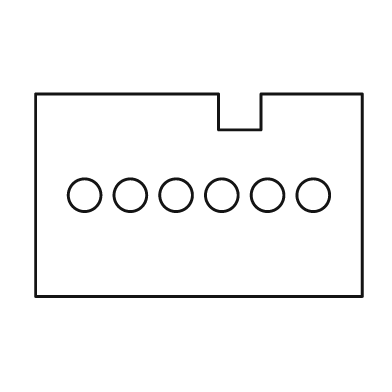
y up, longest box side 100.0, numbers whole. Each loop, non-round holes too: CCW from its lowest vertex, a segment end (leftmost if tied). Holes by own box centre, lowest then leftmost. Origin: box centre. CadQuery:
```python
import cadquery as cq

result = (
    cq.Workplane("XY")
    .moveTo(-50.0, -31.0)
    .lineTo(50.0, -31.0)
    .lineTo(50.0, 31.0)
    .lineTo(19.0, 31.0)
    .lineTo(19.0, 20.0)
    .lineTo(6.0, 20.0)
    .lineTo(6.0, 31.0)
    .lineTo(-50.0, 31.0)
    .close()
    .moveTo(-35.0, 0.0)
    .circle(5.0)
    .moveTo(-21.0, 0.0)
    .circle(5.0)
    .moveTo(-7.0, 0.0)
    .circle(5.0)
    .moveTo(7.0, 0.0)
    .circle(5.0)
    .moveTo(21.0, 0.0)
    .circle(5.0)
    .moveTo(35.0, 0.0)
    .circle(5.0)
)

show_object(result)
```